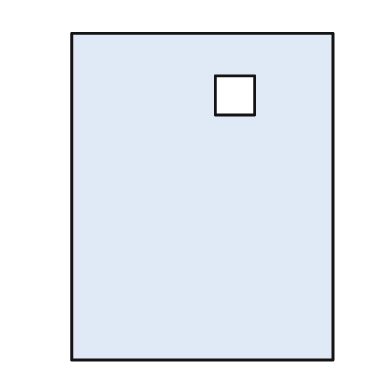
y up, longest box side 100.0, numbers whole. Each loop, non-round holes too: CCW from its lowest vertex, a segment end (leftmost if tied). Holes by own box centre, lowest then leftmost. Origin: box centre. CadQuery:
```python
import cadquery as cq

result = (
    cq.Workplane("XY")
    .moveTo(-40.0, -50.0)
    .lineTo(40.0, -50.0)
    .lineTo(40.0, 50.0)
    .lineTo(-40.0, 50.0)
    .close()
    .moveTo(4.0, 25.0)
    .lineTo(16.0, 25.0)
    .lineTo(16.0, 37.0)
    .lineTo(4.0, 37.0)
    .close()
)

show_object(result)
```